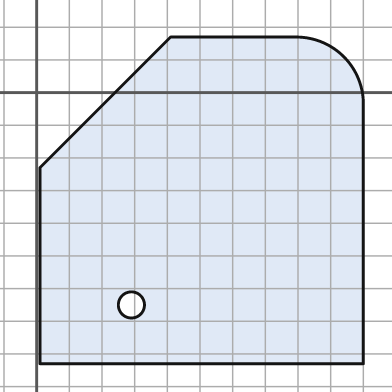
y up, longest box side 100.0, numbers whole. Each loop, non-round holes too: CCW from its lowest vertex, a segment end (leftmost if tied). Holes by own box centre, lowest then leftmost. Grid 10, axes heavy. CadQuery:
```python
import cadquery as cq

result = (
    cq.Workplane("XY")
    .moveTo(1.0, -83.0)
    .lineTo(100.0, -83.0)
    .lineTo(100.0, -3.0)
    .threePointArc((94.0, 11.0), (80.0, 17.0))
    .lineTo(41.0, 17.0)
    .lineTo(1.0, -23.0)
    .close()
    .moveTo(29.0, -65.0)
    .circle(4.0)
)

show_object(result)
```